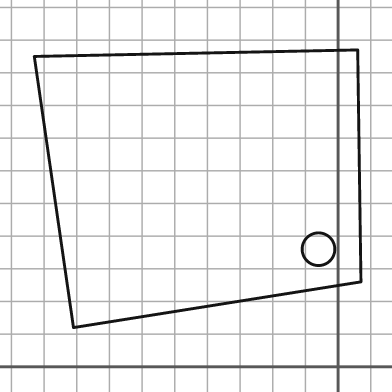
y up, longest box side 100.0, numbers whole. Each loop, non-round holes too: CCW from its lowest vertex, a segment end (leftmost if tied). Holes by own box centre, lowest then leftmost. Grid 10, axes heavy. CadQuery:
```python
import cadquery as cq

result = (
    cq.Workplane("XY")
    .moveTo(-81.0, 12.0)
    .lineTo(7.0, 26.0)
    .lineTo(6.0, 97.0)
    .lineTo(-93.0, 95.0)
    .close()
    .moveTo(-6.0, 36.0)
    .circle(5.0)
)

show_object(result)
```